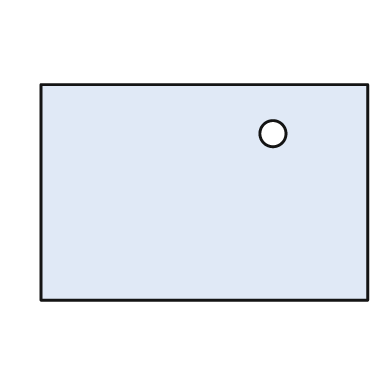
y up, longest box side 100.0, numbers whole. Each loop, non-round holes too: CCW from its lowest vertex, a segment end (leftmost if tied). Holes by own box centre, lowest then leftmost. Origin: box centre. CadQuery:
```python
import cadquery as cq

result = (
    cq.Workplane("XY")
    .moveTo(-50.0, -33.0)
    .lineTo(50.0, -33.0)
    .lineTo(50.0, 33.0)
    .lineTo(-50.0, 33.0)
    .close()
    .moveTo(21.0, 18.0)
    .circle(4.0)
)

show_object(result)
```